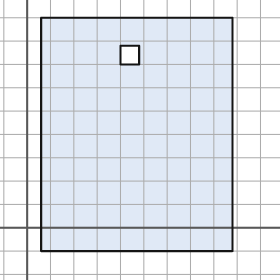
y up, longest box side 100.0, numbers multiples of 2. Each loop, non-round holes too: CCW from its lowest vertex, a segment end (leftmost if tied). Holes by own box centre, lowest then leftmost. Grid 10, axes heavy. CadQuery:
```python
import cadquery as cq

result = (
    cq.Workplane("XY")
    .moveTo(6.0, -10.0)
    .lineTo(88.0, -10.0)
    .lineTo(88.0, 90.0)
    .lineTo(6.0, 90.0)
    .close()
    .moveTo(40.0, 70.0)
    .lineTo(48.0, 70.0)
    .lineTo(48.0, 78.0)
    .lineTo(40.0, 78.0)
    .close()
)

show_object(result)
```